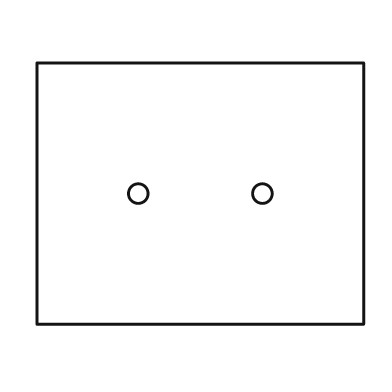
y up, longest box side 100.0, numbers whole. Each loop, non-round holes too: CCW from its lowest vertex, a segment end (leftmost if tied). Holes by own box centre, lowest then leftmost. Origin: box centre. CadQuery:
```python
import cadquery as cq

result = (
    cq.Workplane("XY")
    .moveTo(-50.0, -40.0)
    .lineTo(50.0, -40.0)
    .lineTo(50.0, 40.0)
    .lineTo(-50.0, 40.0)
    .close()
    .moveTo(-19.0, 0.0)
    .circle(3.0)
    .moveTo(19.0, 0.0)
    .circle(3.0)
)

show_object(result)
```